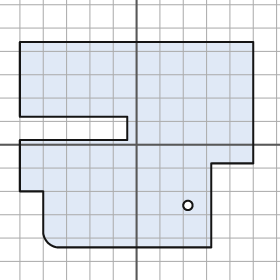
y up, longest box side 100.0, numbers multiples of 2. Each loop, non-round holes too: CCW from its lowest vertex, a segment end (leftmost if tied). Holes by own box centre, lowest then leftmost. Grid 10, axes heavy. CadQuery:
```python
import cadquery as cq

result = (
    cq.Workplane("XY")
    .moveTo(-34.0, -44.0)
    .lineTo(32.0, -44.0)
    .lineTo(32.0, -8.0)
    .lineTo(50.0, -8.0)
    .lineTo(50.0, 44.0)
    .lineTo(-50.0, 44.0)
    .lineTo(-50.0, 12.0)
    .lineTo(-4.0, 12.0)
    .lineTo(-4.0, 2.0)
    .lineTo(-50.0, 2.0)
    .lineTo(-50.0, -20.0)
    .lineTo(-40.0, -20.0)
    .lineTo(-40.0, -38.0)
    .threePointArc((-38.0, -42.0), (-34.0, -44.0))
    .close()
    .moveTo(22.0, -26.0)
    .circle(2.0)
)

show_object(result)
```